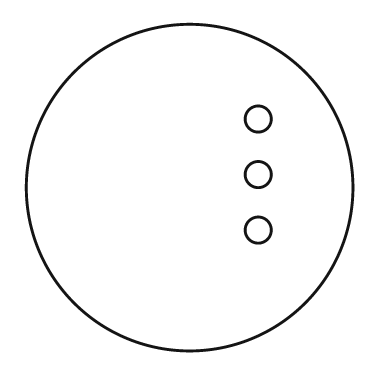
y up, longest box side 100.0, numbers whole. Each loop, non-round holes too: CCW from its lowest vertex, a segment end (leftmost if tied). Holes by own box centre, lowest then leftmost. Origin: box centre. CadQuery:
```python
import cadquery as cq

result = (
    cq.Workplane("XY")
    .moveTo(0.0, 0.0)
    .circle(50.0)
    .moveTo(21.0, -13.0)
    .circle(4.0)
    .moveTo(21.0, 4.0)
    .circle(4.0)
    .moveTo(21.0, 21.0)
    .circle(4.0)
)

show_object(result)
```